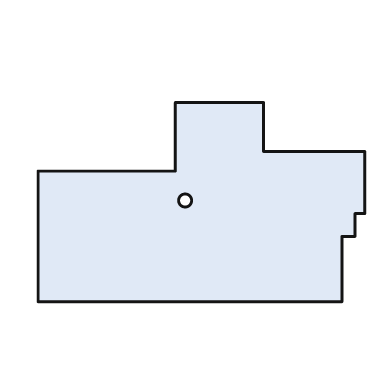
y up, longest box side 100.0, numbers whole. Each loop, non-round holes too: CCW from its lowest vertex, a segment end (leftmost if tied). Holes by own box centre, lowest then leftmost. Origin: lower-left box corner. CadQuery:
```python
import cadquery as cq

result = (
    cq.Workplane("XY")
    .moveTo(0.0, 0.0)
    .lineTo(93.0, 0.0)
    .lineTo(93.0, 20.0)
    .lineTo(97.0, 20.0)
    .lineTo(97.0, 27.0)
    .lineTo(100.0, 27.0)
    .lineTo(100.0, 46.0)
    .lineTo(69.0, 46.0)
    .lineTo(69.0, 61.0)
    .lineTo(42.0, 61.0)
    .lineTo(42.0, 40.0)
    .lineTo(0.0, 40.0)
    .close()
    .moveTo(45.0, 31.0)
    .circle(2.0)
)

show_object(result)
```